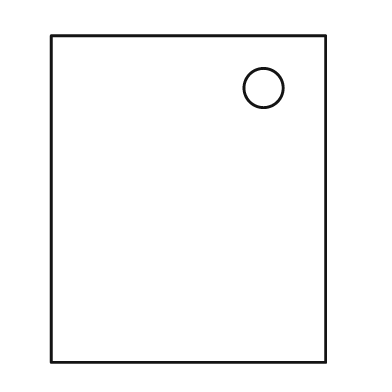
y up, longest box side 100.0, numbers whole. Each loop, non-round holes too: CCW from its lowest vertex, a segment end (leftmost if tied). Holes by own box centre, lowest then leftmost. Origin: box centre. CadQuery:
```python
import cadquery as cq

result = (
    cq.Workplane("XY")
    .moveTo(-42.0, -50.0)
    .lineTo(42.0, -50.0)
    .lineTo(42.0, 50.0)
    .lineTo(-42.0, 50.0)
    .close()
    .moveTo(23.0, 34.0)
    .circle(6.0)
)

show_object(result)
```